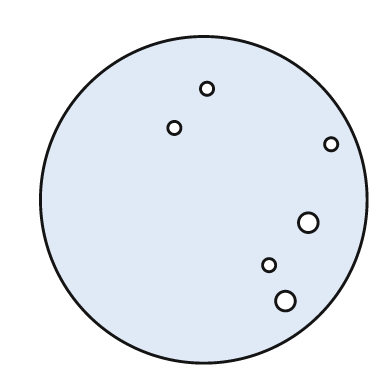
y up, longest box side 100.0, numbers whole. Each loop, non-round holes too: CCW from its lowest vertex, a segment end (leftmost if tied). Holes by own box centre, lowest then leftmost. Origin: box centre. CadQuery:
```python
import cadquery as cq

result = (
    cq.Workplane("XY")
    .moveTo(0.0, 0.0)
    .circle(50.0)
    .moveTo(25.0, -31.0)
    .circle(3.0)
    .moveTo(20.0, -20.0)
    .circle(2.0)
    .moveTo(32.0, -7.0)
    .circle(3.0)
    .moveTo(39.0, 17.0)
    .circle(2.0)
    .moveTo(-9.0, 22.0)
    .circle(2.0)
    .moveTo(1.0, 34.0)
    .circle(2.0)
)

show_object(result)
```